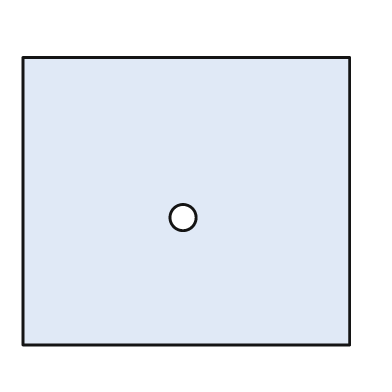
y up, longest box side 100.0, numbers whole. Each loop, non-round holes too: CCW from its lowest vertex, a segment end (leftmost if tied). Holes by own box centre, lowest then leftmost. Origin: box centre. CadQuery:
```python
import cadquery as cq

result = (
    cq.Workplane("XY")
    .moveTo(-50.0, -44.0)
    .lineTo(50.0, -44.0)
    .lineTo(50.0, 44.0)
    .lineTo(-50.0, 44.0)
    .close()
    .moveTo(-1.0, -5.0)
    .circle(4.0)
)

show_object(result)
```